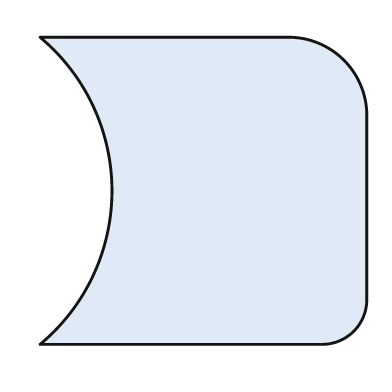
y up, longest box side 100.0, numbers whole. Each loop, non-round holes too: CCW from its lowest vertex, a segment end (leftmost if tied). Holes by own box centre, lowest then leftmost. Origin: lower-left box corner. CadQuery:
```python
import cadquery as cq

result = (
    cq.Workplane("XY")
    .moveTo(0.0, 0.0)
    .lineTo(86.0, 0.0)
    .threePointArc((96.0, 4.0), (100.0, 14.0))
    .lineTo(100.0, 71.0)
    .threePointArc((93.0, 87.0), (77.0, 94.0))
    .lineTo(0.0, 94.0)
    .threePointArc((22.0, 47.0), (0.0, 0.0))
    .close()
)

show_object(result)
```